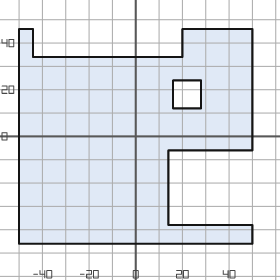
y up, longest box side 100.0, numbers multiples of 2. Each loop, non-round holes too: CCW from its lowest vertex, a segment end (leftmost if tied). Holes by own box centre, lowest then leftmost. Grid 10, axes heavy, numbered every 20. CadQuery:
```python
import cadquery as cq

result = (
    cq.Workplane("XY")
    .moveTo(-50.0, -46.0)
    .lineTo(50.0, -46.0)
    .lineTo(50.0, -38.0)
    .lineTo(14.0, -38.0)
    .lineTo(14.0, -6.0)
    .lineTo(50.0, -6.0)
    .lineTo(50.0, 46.0)
    .lineTo(20.0, 46.0)
    .lineTo(20.0, 34.0)
    .lineTo(-44.0, 34.0)
    .lineTo(-44.0, 46.0)
    .lineTo(-50.0, 46.0)
    .close()
    .moveTo(16.0, 12.0)
    .lineTo(28.0, 12.0)
    .lineTo(28.0, 24.0)
    .lineTo(16.0, 24.0)
    .close()
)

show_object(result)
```